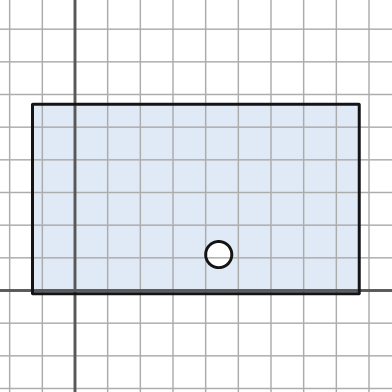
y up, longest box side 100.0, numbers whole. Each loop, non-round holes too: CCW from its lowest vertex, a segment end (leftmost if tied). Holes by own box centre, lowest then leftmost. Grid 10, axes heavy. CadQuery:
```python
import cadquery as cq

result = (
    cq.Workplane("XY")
    .moveTo(-13.0, -1.0)
    .lineTo(87.0, -1.0)
    .lineTo(87.0, 57.0)
    .lineTo(-13.0, 57.0)
    .close()
    .moveTo(44.0, 11.0)
    .circle(4.0)
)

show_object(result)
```